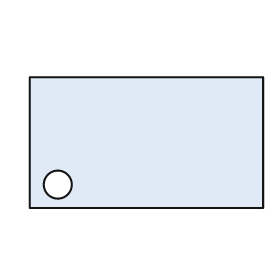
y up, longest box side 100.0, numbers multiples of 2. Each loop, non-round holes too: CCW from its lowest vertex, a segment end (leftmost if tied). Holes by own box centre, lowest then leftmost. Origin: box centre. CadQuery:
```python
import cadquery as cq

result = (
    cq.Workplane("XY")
    .moveTo(-50.0, -28.0)
    .lineTo(50.0, -28.0)
    .lineTo(50.0, 28.0)
    .lineTo(-50.0, 28.0)
    .close()
    .moveTo(-38.0, -18.0)
    .circle(6.0)
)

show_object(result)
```